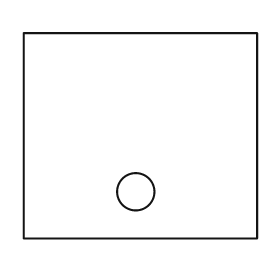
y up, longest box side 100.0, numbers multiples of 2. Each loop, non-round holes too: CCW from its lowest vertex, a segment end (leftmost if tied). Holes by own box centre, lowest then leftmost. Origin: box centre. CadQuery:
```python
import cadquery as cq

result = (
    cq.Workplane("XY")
    .moveTo(-50.0, -44.0)
    .lineTo(50.0, -44.0)
    .lineTo(50.0, 44.0)
    .lineTo(-50.0, 44.0)
    .close()
    .moveTo(-2.0, -24.0)
    .circle(8.0)
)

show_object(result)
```